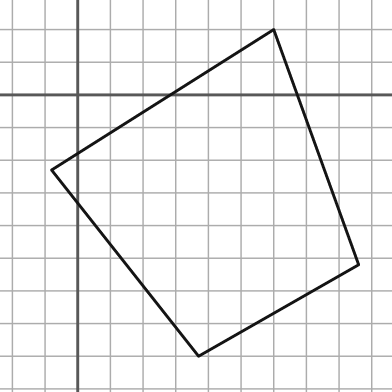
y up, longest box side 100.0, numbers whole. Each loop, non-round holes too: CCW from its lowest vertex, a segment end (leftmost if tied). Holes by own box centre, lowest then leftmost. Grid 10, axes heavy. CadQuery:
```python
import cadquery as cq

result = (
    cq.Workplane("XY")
    .moveTo(37.0, -80.0)
    .lineTo(86.0, -52.0)
    .lineTo(60.0, 20.0)
    .lineTo(-8.0, -23.0)
    .close()
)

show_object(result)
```